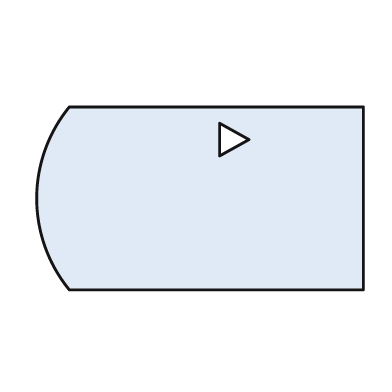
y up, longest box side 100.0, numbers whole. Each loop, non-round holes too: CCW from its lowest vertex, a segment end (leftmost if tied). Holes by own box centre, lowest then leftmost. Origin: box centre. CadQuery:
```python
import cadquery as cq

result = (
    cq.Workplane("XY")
    .moveTo(-40.0, -28.0)
    .lineTo(50.0, -28.0)
    .lineTo(50.0, 28.0)
    .lineTo(-40.0, 28.0)
    .threePointArc((-50.0, 0.0), (-40.0, -28.0))
    .close()
    .moveTo(6.0, 13.0)
    .lineTo(15.0, 18.0)
    .lineTo(6.0, 23.0)
    .close()
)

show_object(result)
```